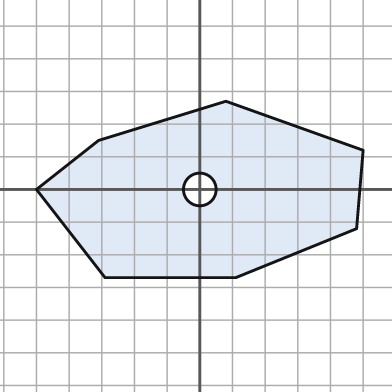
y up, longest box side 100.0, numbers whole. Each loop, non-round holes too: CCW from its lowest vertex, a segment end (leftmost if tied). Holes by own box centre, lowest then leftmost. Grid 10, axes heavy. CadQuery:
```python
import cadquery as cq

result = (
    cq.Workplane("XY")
    .moveTo(-29.0, -27.0)
    .lineTo(11.0, -27.0)
    .lineTo(48.0, -12.0)
    .lineTo(50.0, 12.0)
    .lineTo(8.0, 27.0)
    .lineTo(-31.0, 15.0)
    .lineTo(-50.0, 0.0)
    .close()
    .moveTo(0.0, 0.0)
    .circle(5.0)
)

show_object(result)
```